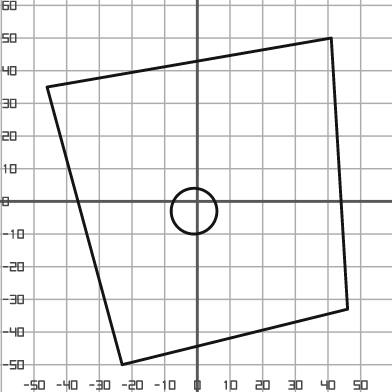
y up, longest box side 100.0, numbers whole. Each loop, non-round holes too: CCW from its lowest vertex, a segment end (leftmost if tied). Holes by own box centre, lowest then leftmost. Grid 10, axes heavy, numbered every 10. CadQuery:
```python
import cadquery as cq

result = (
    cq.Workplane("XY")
    .moveTo(-23.0, -50.0)
    .lineTo(46.0, -33.0)
    .lineTo(41.0, 50.0)
    .lineTo(-46.0, 35.0)
    .close()
    .moveTo(-1.0, -3.0)
    .circle(7.0)
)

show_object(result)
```